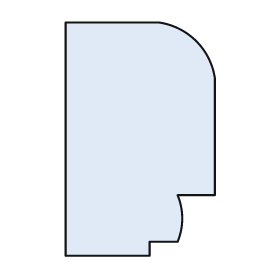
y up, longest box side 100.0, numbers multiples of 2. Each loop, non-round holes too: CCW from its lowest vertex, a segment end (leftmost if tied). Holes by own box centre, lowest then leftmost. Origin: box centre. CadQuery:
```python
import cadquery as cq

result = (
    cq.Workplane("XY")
    .moveTo(-32.0, -50.0)
    .lineTo(4.0, -50.0)
    .lineTo(4.0, -44.0)
    .lineTo(16.0, -44.0)
    .threePointArc((18.0, -34.0), (16.0, -24.0))
    .lineTo(32.0, -24.0)
    .lineTo(32.0, 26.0)
    .threePointArc((24.0, 42.0), (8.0, 50.0))
    .lineTo(-32.0, 50.0)
    .close()
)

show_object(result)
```